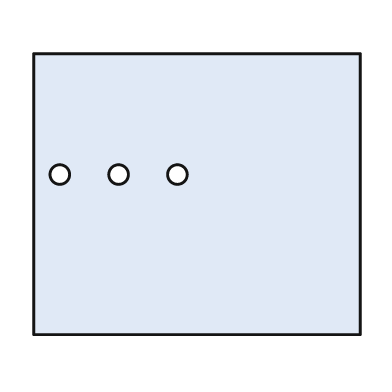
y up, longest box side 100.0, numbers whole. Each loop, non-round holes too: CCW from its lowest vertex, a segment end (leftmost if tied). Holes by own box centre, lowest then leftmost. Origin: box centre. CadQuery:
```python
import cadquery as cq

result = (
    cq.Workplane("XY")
    .moveTo(-50.0, -43.0)
    .lineTo(50.0, -43.0)
    .lineTo(50.0, 43.0)
    .lineTo(-50.0, 43.0)
    .close()
    .moveTo(-42.0, 6.0)
    .circle(3.0)
    .moveTo(-24.0, 6.0)
    .circle(3.0)
    .moveTo(-6.0, 6.0)
    .circle(3.0)
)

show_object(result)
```